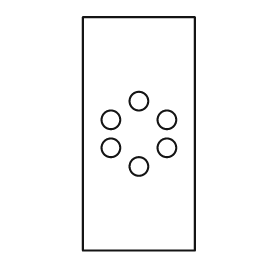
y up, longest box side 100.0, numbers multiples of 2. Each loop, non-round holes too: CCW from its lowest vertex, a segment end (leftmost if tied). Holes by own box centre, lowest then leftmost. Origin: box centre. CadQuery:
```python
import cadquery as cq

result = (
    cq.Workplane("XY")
    .moveTo(-24.0, -50.0)
    .lineTo(24.0, -50.0)
    .lineTo(24.0, 50.0)
    .lineTo(-24.0, 50.0)
    .close()
    .moveTo(0.0, -14.0)
    .circle(4.0)
    .moveTo(-12.0, -6.0)
    .circle(4.0)
    .moveTo(12.0, -6.0)
    .circle(4.0)
    .moveTo(-12.0, 6.0)
    .circle(4.0)
    .moveTo(12.0, 6.0)
    .circle(4.0)
    .moveTo(0.0, 14.0)
    .circle(4.0)
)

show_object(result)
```